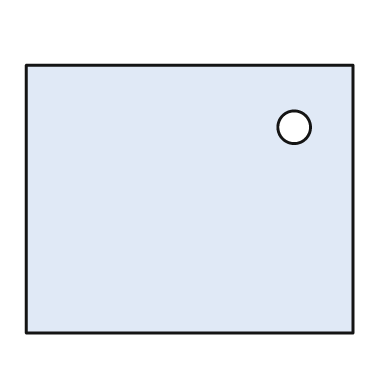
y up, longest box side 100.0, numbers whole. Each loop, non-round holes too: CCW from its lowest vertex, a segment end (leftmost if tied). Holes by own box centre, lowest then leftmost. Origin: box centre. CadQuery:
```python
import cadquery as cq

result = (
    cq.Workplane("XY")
    .moveTo(-50.0, -41.0)
    .lineTo(50.0, -41.0)
    .lineTo(50.0, 41.0)
    .lineTo(-50.0, 41.0)
    .close()
    .moveTo(32.0, 22.0)
    .circle(5.0)
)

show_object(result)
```